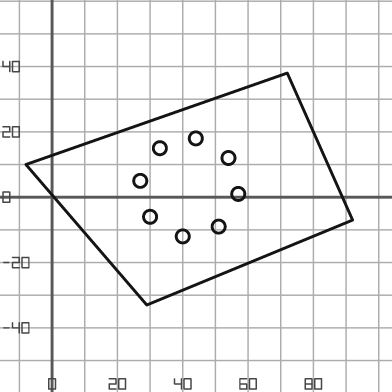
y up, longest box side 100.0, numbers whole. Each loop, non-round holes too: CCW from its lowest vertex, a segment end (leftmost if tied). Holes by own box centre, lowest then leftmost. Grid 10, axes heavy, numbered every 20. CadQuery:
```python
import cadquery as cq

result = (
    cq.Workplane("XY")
    .moveTo(29.0, -33.0)
    .lineTo(92.0, -7.0)
    .lineTo(72.0, 38.0)
    .lineTo(-8.0, 10.0)
    .close()
    .moveTo(40.0, -12.0)
    .circle(2.0)
    .moveTo(51.0, -9.0)
    .circle(2.0)
    .moveTo(30.0, -6.0)
    .circle(2.0)
    .moveTo(57.0, 1.0)
    .circle(2.0)
    .moveTo(27.0, 5.0)
    .circle(2.0)
    .moveTo(54.0, 12.0)
    .circle(2.0)
    .moveTo(33.0, 15.0)
    .circle(2.0)
    .moveTo(44.0, 18.0)
    .circle(2.0)
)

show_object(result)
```